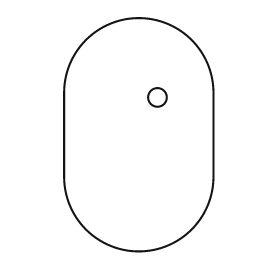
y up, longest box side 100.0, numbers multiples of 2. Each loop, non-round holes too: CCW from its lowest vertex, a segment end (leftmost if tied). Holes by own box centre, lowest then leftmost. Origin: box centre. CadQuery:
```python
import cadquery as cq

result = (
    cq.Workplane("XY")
    .moveTo(-32.0, -18.0)
    .threePointArc((0.0, -50.0), (32.0, -18.0))
    .lineTo(32.0, 18.0)
    .threePointArc((0.0, 50.0), (-32.0, 18.0))
    .close()
    .moveTo(8.0, 16.0)
    .circle(4.0)
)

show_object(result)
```